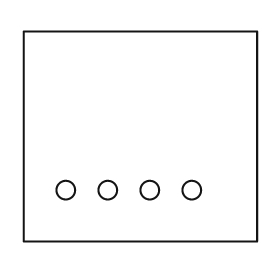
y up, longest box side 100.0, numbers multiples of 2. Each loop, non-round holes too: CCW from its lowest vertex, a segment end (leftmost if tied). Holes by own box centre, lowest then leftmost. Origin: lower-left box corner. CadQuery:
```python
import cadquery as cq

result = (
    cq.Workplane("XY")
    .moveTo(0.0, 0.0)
    .lineTo(100.0, 0.0)
    .lineTo(100.0, 90.0)
    .lineTo(0.0, 90.0)
    .close()
    .moveTo(18.0, 22.0)
    .circle(4.0)
    .moveTo(36.0, 22.0)
    .circle(4.0)
    .moveTo(54.0, 22.0)
    .circle(4.0)
    .moveTo(72.0, 22.0)
    .circle(4.0)
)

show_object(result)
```